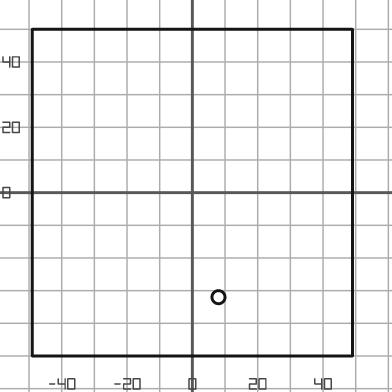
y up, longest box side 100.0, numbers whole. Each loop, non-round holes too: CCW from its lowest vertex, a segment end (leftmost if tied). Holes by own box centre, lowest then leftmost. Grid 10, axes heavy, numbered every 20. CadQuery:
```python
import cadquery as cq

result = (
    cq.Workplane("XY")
    .moveTo(-49.0, -50.0)
    .lineTo(49.0, -50.0)
    .lineTo(49.0, 50.0)
    .lineTo(-49.0, 50.0)
    .close()
    .moveTo(8.0, -32.0)
    .circle(2.0)
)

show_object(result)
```